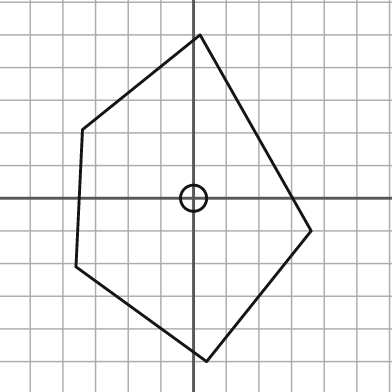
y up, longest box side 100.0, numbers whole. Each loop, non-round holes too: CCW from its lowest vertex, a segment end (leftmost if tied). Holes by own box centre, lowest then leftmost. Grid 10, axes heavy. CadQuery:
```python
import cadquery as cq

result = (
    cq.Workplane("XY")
    .moveTo(4.0, -50.0)
    .lineTo(36.0, -10.0)
    .lineTo(2.0, 50.0)
    .lineTo(-34.0, 21.0)
    .lineTo(-36.0, -21.0)
    .close()
    .moveTo(0.0, 0.0)
    .circle(4.0)
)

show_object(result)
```